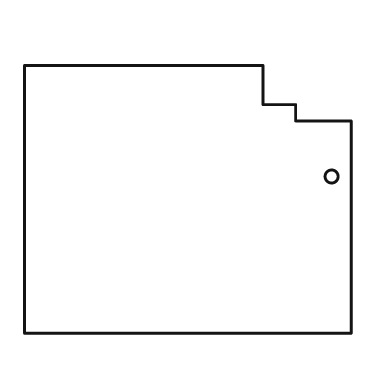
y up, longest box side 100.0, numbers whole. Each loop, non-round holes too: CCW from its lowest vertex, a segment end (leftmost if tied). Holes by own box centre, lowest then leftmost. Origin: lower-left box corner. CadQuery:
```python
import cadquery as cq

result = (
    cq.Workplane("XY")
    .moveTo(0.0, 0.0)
    .lineTo(100.0, 0.0)
    .lineTo(100.0, 65.0)
    .lineTo(83.0, 65.0)
    .lineTo(83.0, 70.0)
    .lineTo(73.0, 70.0)
    .lineTo(73.0, 82.0)
    .lineTo(0.0, 82.0)
    .close()
    .moveTo(94.0, 48.0)
    .circle(2.0)
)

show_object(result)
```